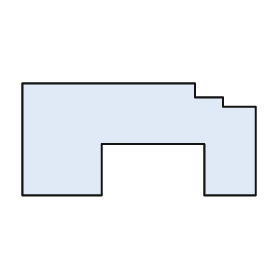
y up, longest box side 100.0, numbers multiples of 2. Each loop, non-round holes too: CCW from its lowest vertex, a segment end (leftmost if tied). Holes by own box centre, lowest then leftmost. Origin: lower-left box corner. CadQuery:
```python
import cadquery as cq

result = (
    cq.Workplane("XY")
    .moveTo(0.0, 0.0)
    .lineTo(34.0, 0.0)
    .lineTo(34.0, 22.0)
    .lineTo(78.0, 22.0)
    .lineTo(78.0, 0.0)
    .lineTo(100.0, 0.0)
    .lineTo(100.0, 38.0)
    .lineTo(86.0, 38.0)
    .lineTo(86.0, 42.0)
    .lineTo(74.0, 42.0)
    .lineTo(74.0, 48.0)
    .lineTo(0.0, 48.0)
    .close()
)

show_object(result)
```